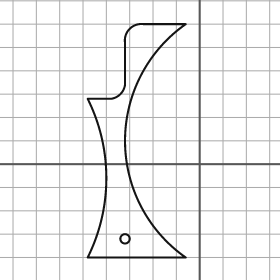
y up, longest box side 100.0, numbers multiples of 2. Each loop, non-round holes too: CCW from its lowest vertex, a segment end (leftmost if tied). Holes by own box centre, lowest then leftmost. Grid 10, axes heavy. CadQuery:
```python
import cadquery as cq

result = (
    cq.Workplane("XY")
    .moveTo(-48.0, -40.0)
    .lineTo(-6.0, -40.0)
    .threePointArc((-32.0, 10.0), (-6.0, 60.0))
    .lineTo(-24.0, 60.0)
    .threePointArc((-30.0, 58.0), (-32.0, 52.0))
    .lineTo(-32.0, 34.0)
    .threePointArc((-34.0, 30.0), (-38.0, 28.0))
    .lineTo(-48.0, 28.0)
    .threePointArc((-40.0, -6.0), (-48.0, -40.0))
    .close()
    .moveTo(-32.0, -32.0)
    .circle(2.0)
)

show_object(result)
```